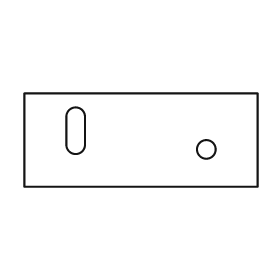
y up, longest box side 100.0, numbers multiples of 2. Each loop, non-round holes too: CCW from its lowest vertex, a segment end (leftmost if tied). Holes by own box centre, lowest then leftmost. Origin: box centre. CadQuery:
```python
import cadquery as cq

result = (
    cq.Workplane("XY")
    .moveTo(-50.0, -20.0)
    .lineTo(50.0, -20.0)
    .lineTo(50.0, 20.0)
    .lineTo(-50.0, 20.0)
    .close()
    .moveTo(28.0, -4.0)
    .circle(4.0)
    .moveTo(-32.0, -2.0)
    .threePointArc((-28.0, -6.0), (-24.0, -2.0))
    .lineTo(-24.0, 10.0)
    .threePointArc((-28.0, 14.0), (-32.0, 10.0))
    .close()
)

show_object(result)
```